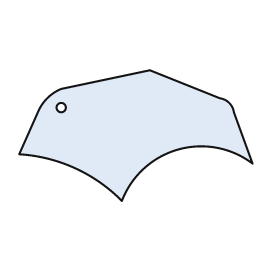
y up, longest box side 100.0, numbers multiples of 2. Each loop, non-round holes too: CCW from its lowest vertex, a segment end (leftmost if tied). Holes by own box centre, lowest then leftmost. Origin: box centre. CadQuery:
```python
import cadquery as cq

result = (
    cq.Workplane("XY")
    .moveTo(-6.0, -28.0)
    .threePointArc((18.0, -6.0), (50.0, -12.0))
    .lineTo(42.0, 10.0)
    .threePointArc((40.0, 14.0), (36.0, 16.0))
    .lineTo(6.0, 28.0)
    .lineTo(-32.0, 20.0)
    .threePointArc((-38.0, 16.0), (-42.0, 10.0))
    .lineTo(-50.0, -8.0)
    .threePointArc((-26.0, -14.0), (-6.0, -28.0))
    .close()
    .moveTo(-32.0, 12.0)
    .circle(2.0)
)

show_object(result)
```